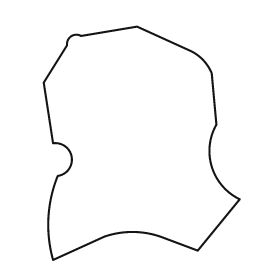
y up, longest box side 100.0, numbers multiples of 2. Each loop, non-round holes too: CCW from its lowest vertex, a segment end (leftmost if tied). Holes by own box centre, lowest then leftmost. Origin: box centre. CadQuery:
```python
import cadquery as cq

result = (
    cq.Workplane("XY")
    .moveTo(-38.0, -50.0)
    .lineTo(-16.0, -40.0)
    .threePointArc((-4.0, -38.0), (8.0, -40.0))
    .lineTo(24.0, -46.0)
    .lineTo(42.0, -24.0)
    .threePointArc((30.0, -10.0), (32.0, 8.0))
    .lineTo(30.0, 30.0)
    .threePointArc((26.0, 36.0), (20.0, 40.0))
    .lineTo(-2.0, 50.0)
    .lineTo(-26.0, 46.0)
    .threePointArc((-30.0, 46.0), (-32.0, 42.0))
    .lineTo(-42.0, 26.0)
    .lineTo(-38.0, 0.0)
    .threePointArc((-30.0, -6.0), (-36.0, -14.0))
    .threePointArc((-40.0, -32.0), (-38.0, -50.0))
    .close()
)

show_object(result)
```